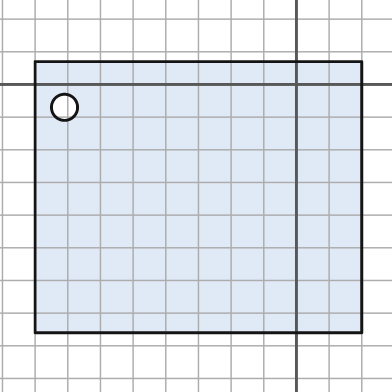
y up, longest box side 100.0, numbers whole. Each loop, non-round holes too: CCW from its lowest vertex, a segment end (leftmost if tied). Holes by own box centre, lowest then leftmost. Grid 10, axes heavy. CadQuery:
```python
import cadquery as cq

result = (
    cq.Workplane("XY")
    .moveTo(-80.0, -76.0)
    .lineTo(20.0, -76.0)
    .lineTo(20.0, 7.0)
    .lineTo(-80.0, 7.0)
    .close()
    .moveTo(-71.0, -7.0)
    .circle(4.0)
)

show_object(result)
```